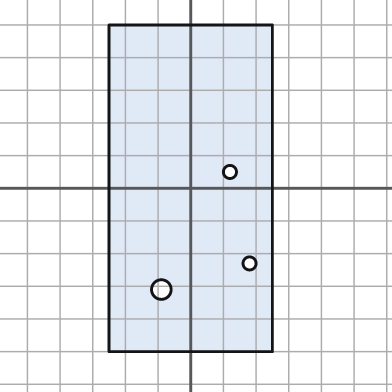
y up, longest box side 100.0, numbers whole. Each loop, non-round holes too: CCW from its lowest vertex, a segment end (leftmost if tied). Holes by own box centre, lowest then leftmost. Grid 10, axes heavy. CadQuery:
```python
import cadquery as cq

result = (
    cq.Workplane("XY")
    .moveTo(-25.0, -50.0)
    .lineTo(25.0, -50.0)
    .lineTo(25.0, 50.0)
    .lineTo(-25.0, 50.0)
    .close()
    .moveTo(-9.0, -31.0)
    .circle(3.0)
    .moveTo(18.0, -23.0)
    .circle(2.0)
    .moveTo(12.0, 5.0)
    .circle(2.0)
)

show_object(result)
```